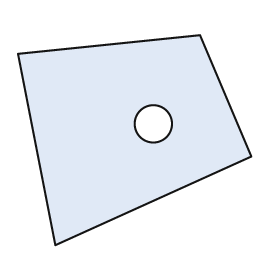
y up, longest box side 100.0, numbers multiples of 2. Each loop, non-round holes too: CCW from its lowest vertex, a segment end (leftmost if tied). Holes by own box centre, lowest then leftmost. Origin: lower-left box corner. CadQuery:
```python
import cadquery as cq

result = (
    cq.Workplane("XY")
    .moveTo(16.0, 0.0)
    .lineTo(100.0, 38.0)
    .lineTo(78.0, 90.0)
    .lineTo(0.0, 82.0)
    .close()
    .moveTo(58.0, 52.0)
    .circle(8.0)
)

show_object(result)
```